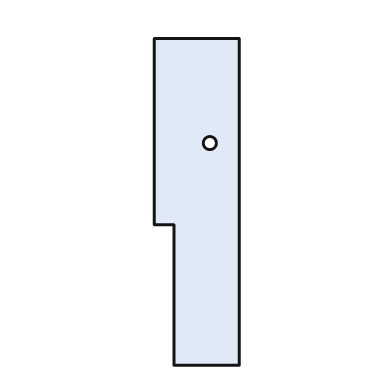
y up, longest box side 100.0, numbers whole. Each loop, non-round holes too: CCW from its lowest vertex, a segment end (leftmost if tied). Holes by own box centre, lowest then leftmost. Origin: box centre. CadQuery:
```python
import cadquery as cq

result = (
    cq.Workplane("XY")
    .moveTo(-7.0, -50.0)
    .lineTo(13.0, -50.0)
    .lineTo(13.0, 50.0)
    .lineTo(-13.0, 50.0)
    .lineTo(-13.0, -7.0)
    .lineTo(-7.0, -7.0)
    .close()
    .moveTo(4.0, 18.0)
    .circle(2.0)
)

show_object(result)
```